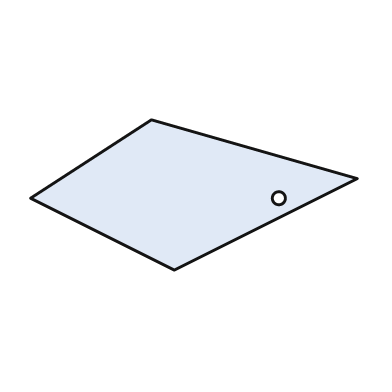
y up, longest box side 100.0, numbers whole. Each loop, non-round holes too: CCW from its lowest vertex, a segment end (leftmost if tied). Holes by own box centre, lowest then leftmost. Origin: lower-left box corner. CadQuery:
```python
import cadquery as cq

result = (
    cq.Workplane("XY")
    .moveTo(44.0, 0.0)
    .lineTo(100.0, 28.0)
    .lineTo(37.0, 46.0)
    .lineTo(0.0, 22.0)
    .close()
    .moveTo(76.0, 22.0)
    .circle(2.0)
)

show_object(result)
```